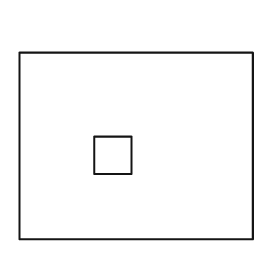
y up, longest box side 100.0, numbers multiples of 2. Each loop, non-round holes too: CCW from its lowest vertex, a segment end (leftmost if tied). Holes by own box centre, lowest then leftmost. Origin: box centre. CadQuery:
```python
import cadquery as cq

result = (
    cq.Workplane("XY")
    .moveTo(-50.0, -40.0)
    .lineTo(50.0, -40.0)
    .lineTo(50.0, 40.0)
    .lineTo(-50.0, 40.0)
    .close()
    .moveTo(-18.0, -12.0)
    .lineTo(-2.0, -12.0)
    .lineTo(-2.0, 4.0)
    .lineTo(-18.0, 4.0)
    .close()
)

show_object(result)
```